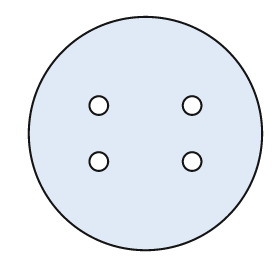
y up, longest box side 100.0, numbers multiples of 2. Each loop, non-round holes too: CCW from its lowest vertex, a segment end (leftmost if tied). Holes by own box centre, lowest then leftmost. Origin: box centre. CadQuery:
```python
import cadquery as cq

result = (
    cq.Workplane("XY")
    .moveTo(0.0, 0.0)
    .circle(50.0)
    .moveTo(-20.0, -12.0)
    .circle(4.0)
    .moveTo(20.0, -12.0)
    .circle(4.0)
    .moveTo(-20.0, 12.0)
    .circle(4.0)
    .moveTo(20.0, 12.0)
    .circle(4.0)
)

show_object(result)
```